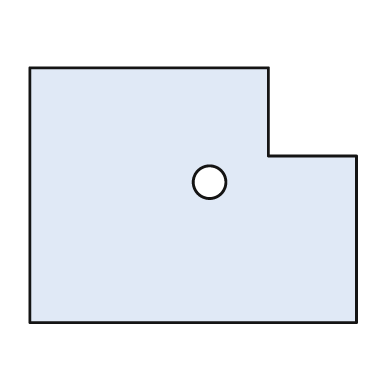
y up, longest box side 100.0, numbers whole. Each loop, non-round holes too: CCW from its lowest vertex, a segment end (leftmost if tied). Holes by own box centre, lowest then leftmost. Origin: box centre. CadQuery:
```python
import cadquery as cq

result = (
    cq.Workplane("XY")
    .moveTo(-50.0, -39.0)
    .lineTo(50.0, -39.0)
    .lineTo(50.0, 12.0)
    .lineTo(23.0, 12.0)
    .lineTo(23.0, 39.0)
    .lineTo(-50.0, 39.0)
    .close()
    .moveTo(5.0, 4.0)
    .circle(5.0)
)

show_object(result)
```